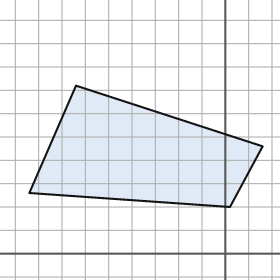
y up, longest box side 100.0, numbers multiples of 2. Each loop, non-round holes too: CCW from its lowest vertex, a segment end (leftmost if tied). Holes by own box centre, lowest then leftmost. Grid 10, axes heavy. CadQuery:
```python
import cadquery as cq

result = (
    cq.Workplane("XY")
    .moveTo(2.0, 20.0)
    .lineTo(16.0, 46.0)
    .lineTo(-64.0, 72.0)
    .lineTo(-84.0, 26.0)
    .close()
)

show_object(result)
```